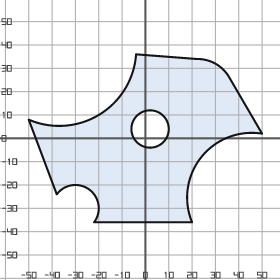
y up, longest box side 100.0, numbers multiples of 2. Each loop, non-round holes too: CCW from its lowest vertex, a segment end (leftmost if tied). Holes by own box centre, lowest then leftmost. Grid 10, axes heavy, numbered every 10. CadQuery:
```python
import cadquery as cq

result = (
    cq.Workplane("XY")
    .moveTo(-22.0, -36.0)
    .lineTo(20.0, -36.0)
    .threePointArc((24.0, -8.0), (50.0, 2.0))
    .lineTo(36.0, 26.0)
    .threePointArc((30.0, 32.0), (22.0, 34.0))
    .lineTo(-4.0, 36.0)
    .threePointArc((-20.0, 10.0), (-50.0, 8.0))
    .lineTo(-38.0, -24.0)
    .threePointArc((-24.0, -22.0), (-22.0, -36.0))
    .close()
    .moveTo(2.0, 4.0)
    .circle(8.0)
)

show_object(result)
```